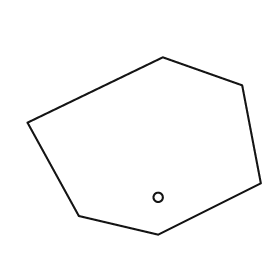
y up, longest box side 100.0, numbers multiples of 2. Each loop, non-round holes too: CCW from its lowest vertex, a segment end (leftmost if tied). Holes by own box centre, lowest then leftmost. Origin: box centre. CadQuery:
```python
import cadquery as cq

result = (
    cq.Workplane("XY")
    .moveTo(6.0, -38.0)
    .lineTo(50.0, -16.0)
    .lineTo(42.0, 26.0)
    .lineTo(8.0, 38.0)
    .lineTo(-50.0, 10.0)
    .lineTo(-28.0, -30.0)
    .close()
    .moveTo(6.0, -22.0)
    .circle(2.0)
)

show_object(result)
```